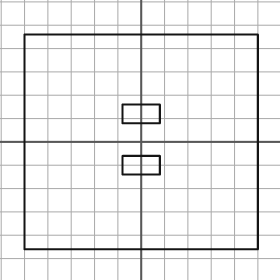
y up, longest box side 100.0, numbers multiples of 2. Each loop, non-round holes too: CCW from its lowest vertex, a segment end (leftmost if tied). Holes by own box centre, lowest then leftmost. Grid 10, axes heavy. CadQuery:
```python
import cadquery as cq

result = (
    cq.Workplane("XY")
    .moveTo(-50.0, -46.0)
    .lineTo(50.0, -46.0)
    .lineTo(50.0, 46.0)
    .lineTo(-50.0, 46.0)
    .close()
    .moveTo(-8.0, -14.0)
    .lineTo(8.0, -14.0)
    .lineTo(8.0, -6.0)
    .lineTo(-8.0, -6.0)
    .close()
    .moveTo(-8.0, 8.0)
    .lineTo(8.0, 8.0)
    .lineTo(8.0, 16.0)
    .lineTo(-8.0, 16.0)
    .close()
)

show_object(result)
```